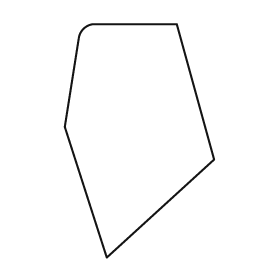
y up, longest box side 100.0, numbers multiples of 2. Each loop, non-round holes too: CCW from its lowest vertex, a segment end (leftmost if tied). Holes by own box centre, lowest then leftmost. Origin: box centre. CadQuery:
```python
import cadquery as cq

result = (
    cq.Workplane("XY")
    .moveTo(-14.0, -50.0)
    .lineTo(32.0, -8.0)
    .lineTo(16.0, 50.0)
    .lineTo(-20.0, 50.0)
    .threePointArc((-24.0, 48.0), (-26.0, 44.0))
    .lineTo(-32.0, 6.0)
    .close()
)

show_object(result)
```